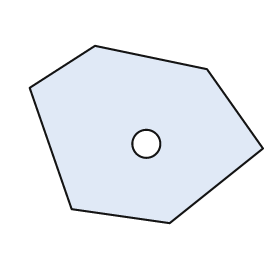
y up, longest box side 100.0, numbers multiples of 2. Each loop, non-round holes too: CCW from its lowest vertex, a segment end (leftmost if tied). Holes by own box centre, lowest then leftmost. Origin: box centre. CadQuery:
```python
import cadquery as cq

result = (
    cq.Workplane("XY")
    .moveTo(10.0, -38.0)
    .lineTo(50.0, -6.0)
    .lineTo(26.0, 28.0)
    .lineTo(-22.0, 38.0)
    .lineTo(-50.0, 20.0)
    .lineTo(-32.0, -32.0)
    .close()
    .moveTo(0.0, -4.0)
    .circle(6.0)
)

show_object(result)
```